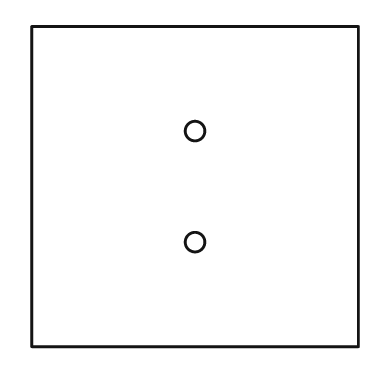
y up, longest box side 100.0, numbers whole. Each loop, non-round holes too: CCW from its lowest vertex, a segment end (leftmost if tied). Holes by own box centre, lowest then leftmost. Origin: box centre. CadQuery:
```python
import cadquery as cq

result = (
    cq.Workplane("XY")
    .moveTo(-50.0, -49.0)
    .lineTo(50.0, -49.0)
    .lineTo(50.0, 49.0)
    .lineTo(-50.0, 49.0)
    .close()
    .moveTo(0.0, -17.0)
    .circle(3.0)
    .moveTo(0.0, 17.0)
    .circle(3.0)
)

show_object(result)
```